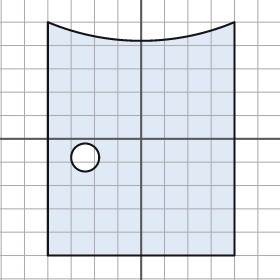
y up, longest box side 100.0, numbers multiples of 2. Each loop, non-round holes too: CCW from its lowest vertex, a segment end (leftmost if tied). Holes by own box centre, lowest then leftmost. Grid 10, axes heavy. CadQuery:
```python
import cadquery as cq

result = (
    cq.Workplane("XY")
    .moveTo(-40.0, -50.0)
    .lineTo(40.0, -50.0)
    .lineTo(40.0, 50.0)
    .threePointArc((0.0, 42.0), (-40.0, 50.0))
    .close()
    .moveTo(-24.0, -8.0)
    .circle(6.0)
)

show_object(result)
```